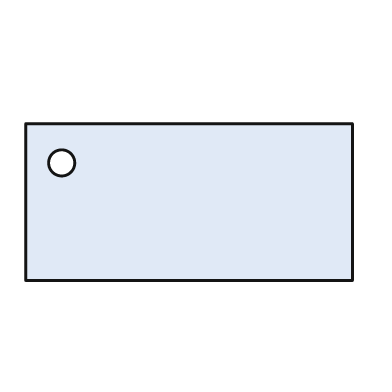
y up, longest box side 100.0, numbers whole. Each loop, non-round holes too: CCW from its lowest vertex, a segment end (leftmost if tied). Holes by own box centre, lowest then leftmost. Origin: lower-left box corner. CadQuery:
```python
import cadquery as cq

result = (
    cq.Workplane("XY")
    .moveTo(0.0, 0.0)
    .lineTo(100.0, 0.0)
    .lineTo(100.0, 48.0)
    .lineTo(0.0, 48.0)
    .close()
    .moveTo(11.0, 36.0)
    .circle(4.0)
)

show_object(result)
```